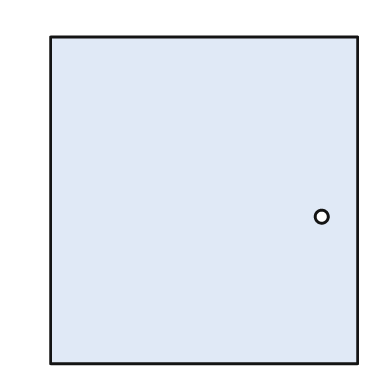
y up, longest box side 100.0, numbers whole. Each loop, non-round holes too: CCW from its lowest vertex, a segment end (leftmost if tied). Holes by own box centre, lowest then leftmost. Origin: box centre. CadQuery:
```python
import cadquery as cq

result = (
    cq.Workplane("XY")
    .moveTo(-47.0, -50.0)
    .lineTo(47.0, -50.0)
    .lineTo(47.0, 50.0)
    .lineTo(-47.0, 50.0)
    .close()
    .moveTo(36.0, -5.0)
    .circle(2.0)
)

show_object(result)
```